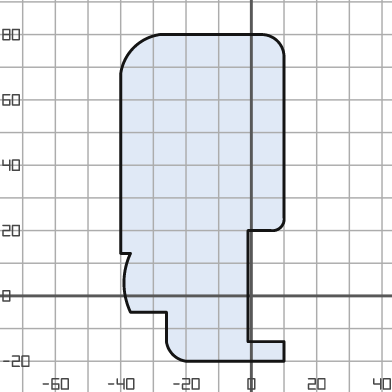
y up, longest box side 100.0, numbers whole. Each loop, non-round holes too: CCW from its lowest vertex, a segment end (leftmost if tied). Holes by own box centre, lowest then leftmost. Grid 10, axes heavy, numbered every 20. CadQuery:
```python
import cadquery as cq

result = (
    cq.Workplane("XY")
    .moveTo(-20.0, -20.0)
    .lineTo(10.0, -20.0)
    .lineTo(10.0, -14.0)
    .lineTo(-1.0, -14.0)
    .lineTo(-1.0, 20.0)
    .lineTo(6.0, 20.0)
    .threePointArc((9.0, 21.0), (10.0, 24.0))
    .lineTo(10.0, 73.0)
    .threePointArc((8.0, 78.0), (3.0, 80.0))
    .lineTo(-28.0, 80.0)
    .threePointArc((-36.0, 76.0), (-40.0, 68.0))
    .lineTo(-40.0, 13.0)
    .lineTo(-37.0, 13.0)
    .threePointArc((-39.0, 4.0), (-37.0, -5.0))
    .lineTo(-26.0, -5.0)
    .lineTo(-26.0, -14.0)
    .threePointArc((-24.0, -18.0), (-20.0, -20.0))
    .close()
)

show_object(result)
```